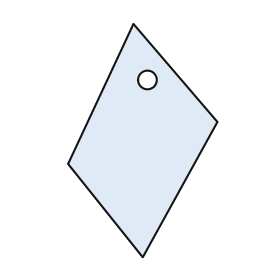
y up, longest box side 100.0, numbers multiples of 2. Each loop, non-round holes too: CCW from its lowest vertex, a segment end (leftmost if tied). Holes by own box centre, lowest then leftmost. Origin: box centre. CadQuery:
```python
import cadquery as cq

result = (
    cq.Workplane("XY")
    .moveTo(0.0, -50.0)
    .lineTo(32.0, 8.0)
    .lineTo(-4.0, 50.0)
    .lineTo(-32.0, -10.0)
    .close()
    .moveTo(2.0, 26.0)
    .circle(4.0)
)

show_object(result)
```